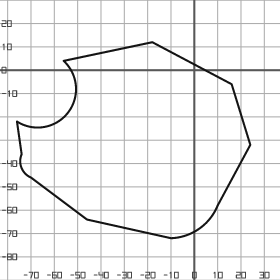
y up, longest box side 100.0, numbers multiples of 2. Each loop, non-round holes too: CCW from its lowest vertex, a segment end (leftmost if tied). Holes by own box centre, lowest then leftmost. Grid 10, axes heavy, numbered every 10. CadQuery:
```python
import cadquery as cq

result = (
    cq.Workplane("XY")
    .moveTo(-10.0, -72.0)
    .threePointArc((2.0, -68.0), (10.0, -58.0))
    .lineTo(24.0, -32.0)
    .lineTo(16.0, -6.0)
    .lineTo(-18.0, 12.0)
    .lineTo(-56.0, 4.0)
    .threePointArc((-54.0, -18.0), (-76.0, -22.0))
    .lineTo(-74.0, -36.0)
    .threePointArc((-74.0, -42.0), (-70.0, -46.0))
    .lineTo(-46.0, -64.0)
    .close()
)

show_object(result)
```